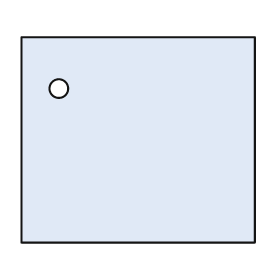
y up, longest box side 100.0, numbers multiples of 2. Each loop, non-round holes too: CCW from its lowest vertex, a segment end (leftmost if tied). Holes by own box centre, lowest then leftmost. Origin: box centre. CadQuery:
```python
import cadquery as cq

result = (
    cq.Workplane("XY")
    .moveTo(-50.0, -44.0)
    .lineTo(50.0, -44.0)
    .lineTo(50.0, 44.0)
    .lineTo(-50.0, 44.0)
    .close()
    .moveTo(-34.0, 22.0)
    .circle(4.0)
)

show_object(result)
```